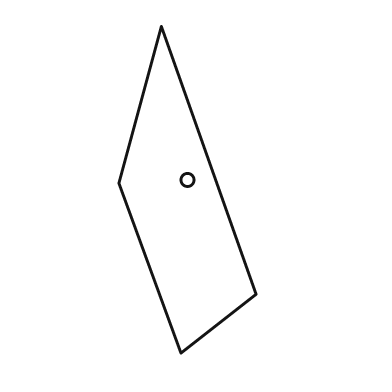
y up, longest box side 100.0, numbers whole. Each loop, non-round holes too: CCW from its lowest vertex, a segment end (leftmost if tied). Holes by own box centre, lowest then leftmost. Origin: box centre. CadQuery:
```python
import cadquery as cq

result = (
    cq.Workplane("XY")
    .moveTo(-2.0, -50.0)
    .lineTo(21.0, -32.0)
    .lineTo(-8.0, 50.0)
    .lineTo(-21.0, 2.0)
    .close()
    .moveTo(0.0, 3.0)
    .circle(2.0)
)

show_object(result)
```